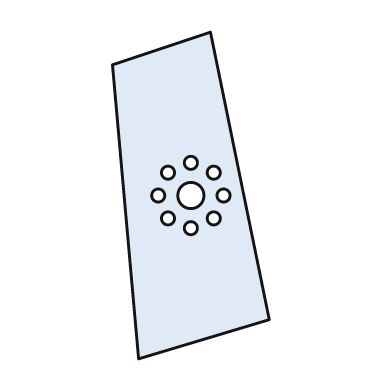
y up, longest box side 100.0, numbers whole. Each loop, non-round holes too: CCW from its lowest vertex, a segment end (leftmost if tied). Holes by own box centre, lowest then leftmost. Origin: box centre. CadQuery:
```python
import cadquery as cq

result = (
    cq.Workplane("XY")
    .moveTo(-16.0, -50.0)
    .lineTo(24.0, -38.0)
    .lineTo(6.0, 50.0)
    .lineTo(-24.0, 40.0)
    .close()
    .moveTo(0.0, -10.0)
    .circle(2.0)
    .moveTo(-7.0, -7.0)
    .circle(2.0)
    .moveTo(7.0, -7.0)
    .circle(2.0)
    .moveTo(-10.0, 0.0)
    .circle(2.0)
    .moveTo(0.0, 0.0)
    .circle(4.0)
    .moveTo(10.0, 0.0)
    .circle(2.0)
    .moveTo(-7.0, 7.0)
    .circle(2.0)
    .moveTo(7.0, 7.0)
    .circle(2.0)
    .moveTo(0.0, 10.0)
    .circle(2.0)
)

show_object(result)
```